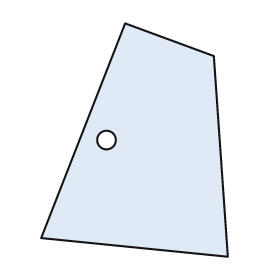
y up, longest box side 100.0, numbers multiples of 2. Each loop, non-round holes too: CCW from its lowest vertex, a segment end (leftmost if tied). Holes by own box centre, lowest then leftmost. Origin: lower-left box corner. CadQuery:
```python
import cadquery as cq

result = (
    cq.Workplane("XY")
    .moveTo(80.0, 0.0)
    .lineTo(74.0, 86.0)
    .lineTo(36.0, 100.0)
    .lineTo(0.0, 8.0)
    .close()
    .moveTo(28.0, 50.0)
    .circle(4.0)
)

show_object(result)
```